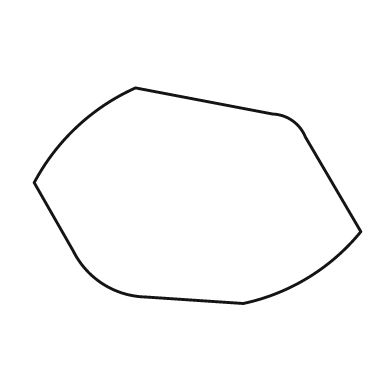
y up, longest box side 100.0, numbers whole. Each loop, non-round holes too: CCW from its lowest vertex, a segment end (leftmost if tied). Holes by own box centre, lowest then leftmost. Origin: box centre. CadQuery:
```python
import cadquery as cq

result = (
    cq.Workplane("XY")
    .moveTo(14.0, -33.0)
    .threePointArc((34.0, -25.0), (50.0, -11.0))
    .lineTo(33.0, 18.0)
    .threePointArc((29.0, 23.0), (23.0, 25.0))
    .lineTo(-19.0, 33.0)
    .threePointArc((-37.0, 21.0), (-50.0, 4.0))
    .lineTo(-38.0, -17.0)
    .threePointArc((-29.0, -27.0), (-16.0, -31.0))
    .close()
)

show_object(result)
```